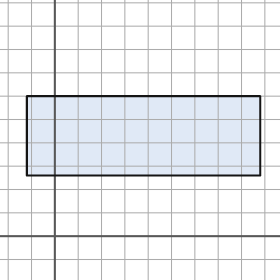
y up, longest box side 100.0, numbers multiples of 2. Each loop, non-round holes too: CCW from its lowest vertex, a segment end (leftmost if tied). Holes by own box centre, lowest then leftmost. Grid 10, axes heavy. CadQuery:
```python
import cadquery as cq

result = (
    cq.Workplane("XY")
    .moveTo(-12.0, 26.0)
    .lineTo(88.0, 26.0)
    .lineTo(88.0, 60.0)
    .lineTo(-12.0, 60.0)
    .close()
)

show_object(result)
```